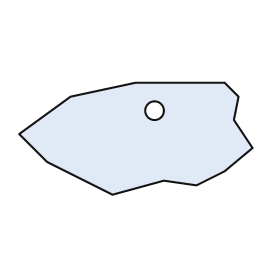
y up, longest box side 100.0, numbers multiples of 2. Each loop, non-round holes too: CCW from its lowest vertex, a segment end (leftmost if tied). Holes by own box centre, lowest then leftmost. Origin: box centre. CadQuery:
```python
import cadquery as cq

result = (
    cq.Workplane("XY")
    .moveTo(-10.0, -24.0)
    .lineTo(12.0, -18.0)
    .lineTo(26.0, -20.0)
    .lineTo(38.0, -14.0)
    .lineTo(50.0, -4.0)
    .lineTo(42.0, 8.0)
    .lineTo(44.0, 18.0)
    .lineTo(38.0, 24.0)
    .lineTo(0.0, 24.0)
    .lineTo(-28.0, 18.0)
    .lineTo(-50.0, 2.0)
    .lineTo(-38.0, -10.0)
    .close()
    .moveTo(8.0, 12.0)
    .circle(4.0)
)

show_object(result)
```